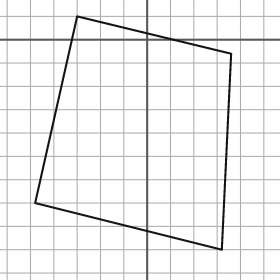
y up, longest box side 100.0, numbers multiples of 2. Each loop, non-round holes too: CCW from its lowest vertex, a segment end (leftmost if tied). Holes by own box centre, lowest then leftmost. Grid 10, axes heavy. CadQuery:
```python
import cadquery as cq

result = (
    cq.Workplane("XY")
    .moveTo(32.0, -90.0)
    .lineTo(36.0, -6.0)
    .lineTo(-30.0, 10.0)
    .lineTo(-48.0, -70.0)
    .close()
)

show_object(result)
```